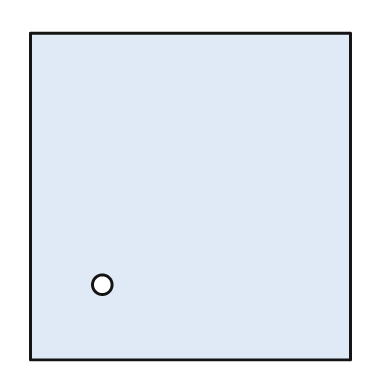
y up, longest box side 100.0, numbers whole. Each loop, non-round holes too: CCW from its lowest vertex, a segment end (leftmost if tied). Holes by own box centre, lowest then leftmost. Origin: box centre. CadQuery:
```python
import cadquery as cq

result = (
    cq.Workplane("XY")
    .moveTo(-49.0, -50.0)
    .lineTo(49.0, -50.0)
    .lineTo(49.0, 50.0)
    .lineTo(-49.0, 50.0)
    .close()
    .moveTo(-27.0, -27.0)
    .circle(3.0)
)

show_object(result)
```